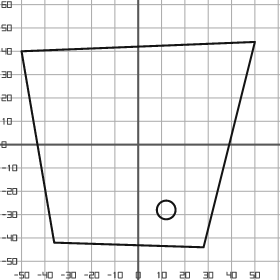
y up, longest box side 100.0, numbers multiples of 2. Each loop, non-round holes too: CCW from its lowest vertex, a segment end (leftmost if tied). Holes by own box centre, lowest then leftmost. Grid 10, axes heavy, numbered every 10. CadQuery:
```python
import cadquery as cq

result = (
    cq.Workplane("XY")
    .moveTo(28.0, -44.0)
    .lineTo(50.0, 44.0)
    .lineTo(-50.0, 40.0)
    .lineTo(-36.0, -42.0)
    .close()
    .moveTo(12.0, -28.0)
    .circle(4.0)
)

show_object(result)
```